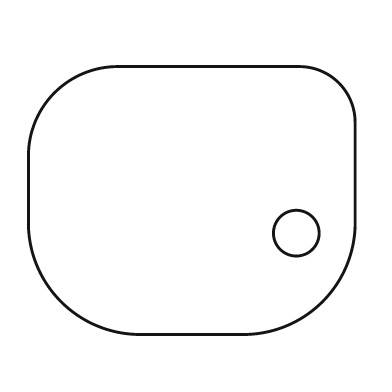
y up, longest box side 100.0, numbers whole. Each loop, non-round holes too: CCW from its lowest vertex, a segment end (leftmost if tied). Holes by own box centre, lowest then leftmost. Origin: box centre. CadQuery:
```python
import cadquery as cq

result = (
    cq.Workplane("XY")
    .moveTo(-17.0, -41.0)
    .lineTo(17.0, -41.0)
    .threePointArc((40.0, -31.0), (50.0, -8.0))
    .lineTo(50.0, 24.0)
    .threePointArc((45.0, 36.0), (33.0, 41.0))
    .lineTo(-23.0, 41.0)
    .threePointArc((-42.0, 33.0), (-50.0, 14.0))
    .lineTo(-50.0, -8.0)
    .threePointArc((-40.0, -31.0), (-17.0, -41.0))
    .close()
    .moveTo(32.0, -10.0)
    .circle(7.0)
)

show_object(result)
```